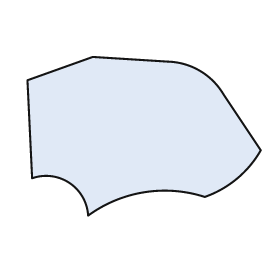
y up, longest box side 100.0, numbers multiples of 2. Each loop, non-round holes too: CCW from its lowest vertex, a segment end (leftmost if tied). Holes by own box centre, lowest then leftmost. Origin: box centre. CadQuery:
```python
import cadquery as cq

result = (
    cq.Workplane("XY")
    .moveTo(-24.0, -34.0)
    .threePointArc((0.0, -24.0), (26.0, -26.0))
    .threePointArc((40.0, -18.0), (50.0, -6.0))
    .lineTo(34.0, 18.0)
    .threePointArc((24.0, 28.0), (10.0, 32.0))
    .lineTo(-22.0, 34.0)
    .lineTo(-50.0, 24.0)
    .lineTo(-48.0, -18.0)
    .threePointArc((-32.0, -20.0), (-24.0, -34.0))
    .close()
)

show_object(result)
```